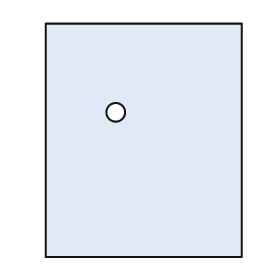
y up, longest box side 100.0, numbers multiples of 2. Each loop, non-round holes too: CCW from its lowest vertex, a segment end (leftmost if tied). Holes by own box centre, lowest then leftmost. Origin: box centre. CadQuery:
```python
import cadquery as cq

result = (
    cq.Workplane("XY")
    .moveTo(-42.0, -50.0)
    .lineTo(42.0, -50.0)
    .lineTo(42.0, 50.0)
    .lineTo(-42.0, 50.0)
    .close()
    .moveTo(-12.0, 12.0)
    .circle(4.0)
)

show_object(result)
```